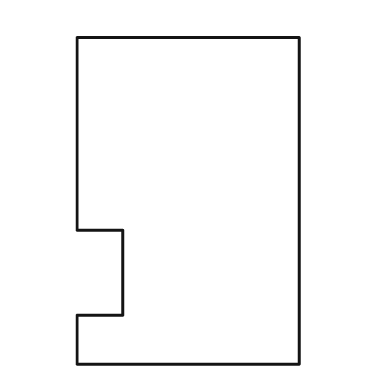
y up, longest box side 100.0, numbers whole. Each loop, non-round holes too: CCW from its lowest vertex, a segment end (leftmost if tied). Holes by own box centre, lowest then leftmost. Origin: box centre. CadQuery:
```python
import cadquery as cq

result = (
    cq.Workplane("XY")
    .moveTo(-34.0, -50.0)
    .lineTo(34.0, -50.0)
    .lineTo(34.0, 50.0)
    .lineTo(-34.0, 50.0)
    .lineTo(-34.0, -9.0)
    .lineTo(-20.0, -9.0)
    .lineTo(-20.0, -35.0)
    .lineTo(-34.0, -35.0)
    .close()
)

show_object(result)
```